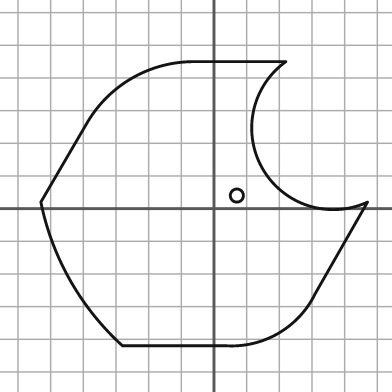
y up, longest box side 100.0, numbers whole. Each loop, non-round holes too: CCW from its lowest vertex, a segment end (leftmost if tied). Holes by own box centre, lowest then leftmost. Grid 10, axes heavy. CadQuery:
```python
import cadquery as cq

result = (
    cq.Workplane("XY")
    .moveTo(-28.0, -42.0)
    .lineTo(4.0, -42.0)
    .threePointArc((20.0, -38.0), (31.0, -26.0))
    .lineTo(47.0, 2.0)
    .threePointArc((15.0, 12.0), (22.0, 45.0))
    .lineTo(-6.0, 45.0)
    .threePointArc((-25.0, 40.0), (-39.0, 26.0))
    .lineTo(-53.0, 2.0)
    .threePointArc((-44.0, -22.0), (-28.0, -42.0))
    .close()
    .moveTo(7.0, 4.0)
    .circle(2.0)
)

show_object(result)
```